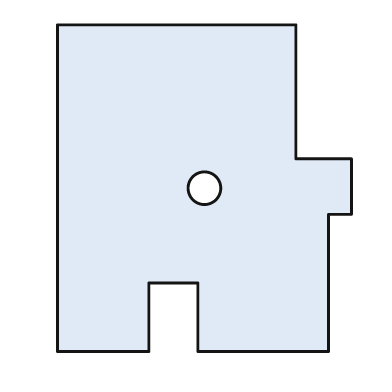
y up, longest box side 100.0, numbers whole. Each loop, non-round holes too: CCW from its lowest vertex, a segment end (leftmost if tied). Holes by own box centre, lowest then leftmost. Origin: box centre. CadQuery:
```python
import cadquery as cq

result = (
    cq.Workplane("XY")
    .moveTo(-45.0, -50.0)
    .lineTo(-17.0, -50.0)
    .lineTo(-17.0, -29.0)
    .lineTo(-2.0, -29.0)
    .lineTo(-2.0, -50.0)
    .lineTo(38.0, -50.0)
    .lineTo(38.0, -8.0)
    .lineTo(45.0, -8.0)
    .lineTo(45.0, 9.0)
    .lineTo(28.0, 9.0)
    .lineTo(28.0, 50.0)
    .lineTo(-45.0, 50.0)
    .close()
    .moveTo(0.0, 0.0)
    .circle(5.0)
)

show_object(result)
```